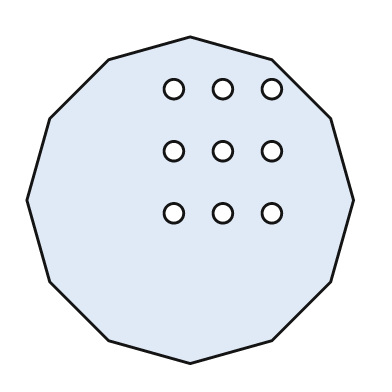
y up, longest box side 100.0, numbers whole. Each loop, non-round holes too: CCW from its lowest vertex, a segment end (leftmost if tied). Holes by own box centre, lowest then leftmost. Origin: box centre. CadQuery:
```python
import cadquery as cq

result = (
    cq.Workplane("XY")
    .moveTo(0.0, -50.0)
    .lineTo(25.0, -43.0)
    .lineTo(43.0, -25.0)
    .lineTo(50.0, 0.0)
    .lineTo(43.0, 25.0)
    .lineTo(25.0, 43.0)
    .lineTo(0.0, 50.0)
    .lineTo(-25.0, 43.0)
    .lineTo(-43.0, 25.0)
    .lineTo(-50.0, 0.0)
    .lineTo(-43.0, -25.0)
    .lineTo(-25.0, -43.0)
    .close()
    .moveTo(-5.0, -4.0)
    .circle(3.0)
    .moveTo(10.0, -4.0)
    .circle(3.0)
    .moveTo(25.0, -4.0)
    .circle(3.0)
    .moveTo(-5.0, 15.0)
    .circle(3.0)
    .moveTo(10.0, 15.0)
    .circle(3.0)
    .moveTo(25.0, 15.0)
    .circle(3.0)
    .moveTo(-5.0, 34.0)
    .circle(3.0)
    .moveTo(10.0, 34.0)
    .circle(3.0)
    .moveTo(25.0, 34.0)
    .circle(3.0)
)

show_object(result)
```